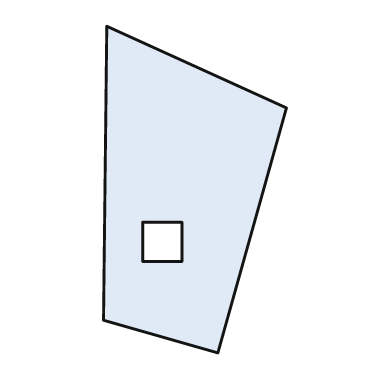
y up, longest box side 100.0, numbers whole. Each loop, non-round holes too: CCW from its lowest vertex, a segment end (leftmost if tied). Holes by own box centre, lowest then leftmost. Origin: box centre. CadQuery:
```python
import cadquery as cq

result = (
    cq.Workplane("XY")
    .moveTo(7.0, -50.0)
    .lineTo(28.0, 25.0)
    .lineTo(-27.0, 50.0)
    .lineTo(-28.0, -40.0)
    .close()
    .moveTo(-16.0, -22.0)
    .lineTo(-4.0, -22.0)
    .lineTo(-4.0, -10.0)
    .lineTo(-16.0, -10.0)
    .close()
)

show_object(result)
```